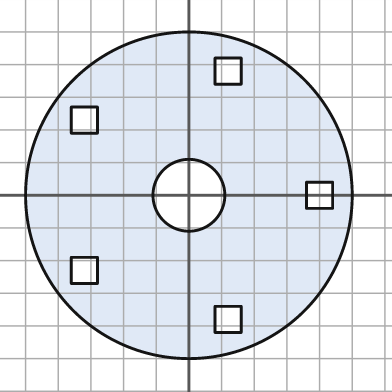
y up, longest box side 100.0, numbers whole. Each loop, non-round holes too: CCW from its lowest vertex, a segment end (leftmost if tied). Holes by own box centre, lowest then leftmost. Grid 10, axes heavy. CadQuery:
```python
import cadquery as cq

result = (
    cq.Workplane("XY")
    .moveTo(0.0, 0.0)
    .circle(50.0)
    .moveTo(8.0, -42.0)
    .lineTo(16.0, -42.0)
    .lineTo(16.0, -34.0)
    .lineTo(8.0, -34.0)
    .close()
    .moveTo(-36.0, -27.0)
    .lineTo(-28.0, -27.0)
    .lineTo(-28.0, -19.0)
    .lineTo(-36.0, -19.0)
    .close()
    .moveTo(0.0, 0.0)
    .circle(11.0)
    .moveTo(36.0, -4.0)
    .lineTo(44.0, -4.0)
    .lineTo(44.0, 4.0)
    .lineTo(36.0, 4.0)
    .close()
    .moveTo(-36.0, 19.0)
    .lineTo(-28.0, 19.0)
    .lineTo(-28.0, 27.0)
    .lineTo(-36.0, 27.0)
    .close()
    .moveTo(8.0, 34.0)
    .lineTo(16.0, 34.0)
    .lineTo(16.0, 42.0)
    .lineTo(8.0, 42.0)
    .close()
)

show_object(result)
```